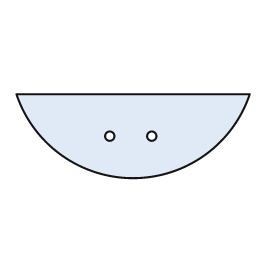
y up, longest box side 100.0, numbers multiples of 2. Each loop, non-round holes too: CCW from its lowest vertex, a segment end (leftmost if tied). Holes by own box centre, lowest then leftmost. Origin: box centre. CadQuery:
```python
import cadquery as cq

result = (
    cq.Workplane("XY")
    .moveTo(-50.0, 18.0)
    .threePointArc((0.0, -18.0), (50.0, 18.0))
    .close()
    .moveTo(-10.0, 0.0)
    .circle(2.0)
    .moveTo(8.0, 0.0)
    .circle(2.0)
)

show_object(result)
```